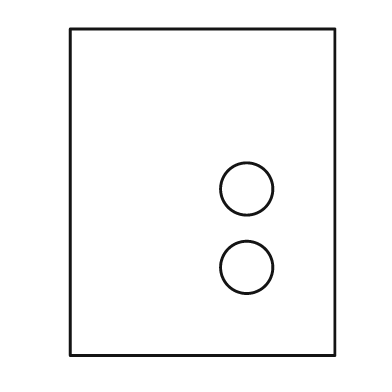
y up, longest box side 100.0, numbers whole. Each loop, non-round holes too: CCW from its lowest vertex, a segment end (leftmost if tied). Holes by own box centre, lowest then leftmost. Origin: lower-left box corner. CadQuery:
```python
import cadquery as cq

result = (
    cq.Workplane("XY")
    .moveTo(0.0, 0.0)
    .lineTo(81.0, 0.0)
    .lineTo(81.0, 100.0)
    .lineTo(0.0, 100.0)
    .close()
    .moveTo(54.0, 27.0)
    .circle(8.0)
    .moveTo(54.0, 51.0)
    .circle(8.0)
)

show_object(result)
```